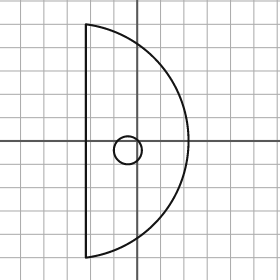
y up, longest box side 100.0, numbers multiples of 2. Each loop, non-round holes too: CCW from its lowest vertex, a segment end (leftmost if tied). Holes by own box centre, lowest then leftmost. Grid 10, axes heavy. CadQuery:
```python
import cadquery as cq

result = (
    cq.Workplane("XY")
    .moveTo(-22.0, -50.0)
    .threePointArc((22.0, 0.0), (-22.0, 50.0))
    .close()
    .moveTo(-4.0, -4.0)
    .circle(6.0)
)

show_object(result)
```